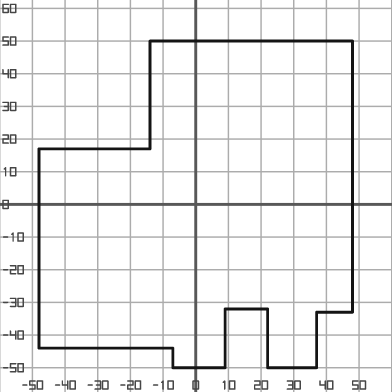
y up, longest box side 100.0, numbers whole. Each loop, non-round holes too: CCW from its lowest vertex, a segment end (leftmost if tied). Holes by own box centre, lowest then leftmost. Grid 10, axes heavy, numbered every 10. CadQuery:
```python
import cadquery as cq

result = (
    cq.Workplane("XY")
    .moveTo(-7.0, -50.0)
    .lineTo(9.0, -50.0)
    .lineTo(9.0, -32.0)
    .lineTo(22.0, -32.0)
    .lineTo(22.0, -50.0)
    .lineTo(37.0, -50.0)
    .lineTo(37.0, -33.0)
    .lineTo(48.0, -33.0)
    .lineTo(48.0, 50.0)
    .lineTo(-14.0, 50.0)
    .lineTo(-14.0, 17.0)
    .lineTo(-48.0, 17.0)
    .lineTo(-48.0, -44.0)
    .lineTo(-7.0, -44.0)
    .close()
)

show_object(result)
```